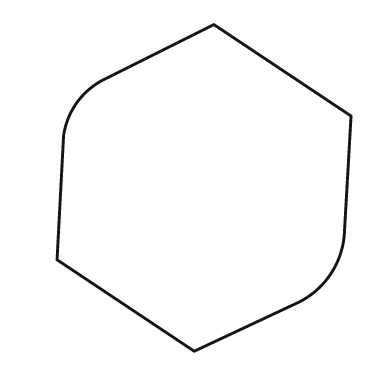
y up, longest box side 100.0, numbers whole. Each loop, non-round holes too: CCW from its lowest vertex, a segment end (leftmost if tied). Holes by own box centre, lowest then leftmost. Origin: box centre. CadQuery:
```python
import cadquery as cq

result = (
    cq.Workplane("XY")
    .moveTo(-3.0, -50.0)
    .lineTo(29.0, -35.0)
    .threePointArc((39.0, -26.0), (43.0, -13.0))
    .lineTo(45.0, 22.0)
    .lineTo(3.0, 50.0)
    .lineTo(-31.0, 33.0)
    .threePointArc((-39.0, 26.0), (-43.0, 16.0))
    .lineTo(-45.0, -22.0)
    .close()
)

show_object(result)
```